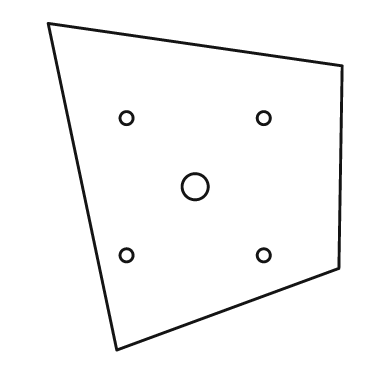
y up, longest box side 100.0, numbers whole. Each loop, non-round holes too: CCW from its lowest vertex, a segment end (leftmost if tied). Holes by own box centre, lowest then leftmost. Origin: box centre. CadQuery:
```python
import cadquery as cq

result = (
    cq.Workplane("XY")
    .moveTo(-24.0, -50.0)
    .lineTo(44.0, -25.0)
    .lineTo(45.0, 37.0)
    .lineTo(-45.0, 50.0)
    .close()
    .moveTo(-21.0, -21.0)
    .circle(2.0)
    .moveTo(21.0, -21.0)
    .circle(2.0)
    .moveTo(0.0, 0.0)
    .circle(4.0)
    .moveTo(-21.0, 21.0)
    .circle(2.0)
    .moveTo(21.0, 21.0)
    .circle(2.0)
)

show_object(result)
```